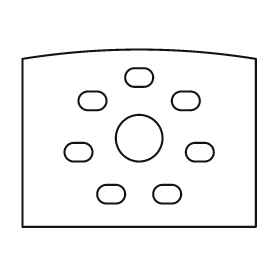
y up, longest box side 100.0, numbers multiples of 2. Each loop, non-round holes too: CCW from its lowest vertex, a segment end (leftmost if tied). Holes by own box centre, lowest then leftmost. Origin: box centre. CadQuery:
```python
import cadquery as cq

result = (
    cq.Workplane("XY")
    .moveTo(-50.0, -38.0)
    .lineTo(50.0, -38.0)
    .lineTo(50.0, 34.0)
    .threePointArc((0.0, 38.0), (-50.0, 34.0))
    .close()
    .moveTo(-14.0, -28.0)
    .lineTo(-10.0, -28.0)
    .threePointArc((-6.0, -24.0), (-10.0, -20.0))
    .lineTo(-14.0, -20.0)
    .threePointArc((-18.0, -24.0), (-14.0, -28.0))
    .close()
    .moveTo(10.0, -28.0)
    .lineTo(14.0, -28.0)
    .threePointArc((18.0, -24.0), (14.0, -20.0))
    .lineTo(10.0, -20.0)
    .threePointArc((6.0, -24.0), (10.0, -28.0))
    .close()
    .moveTo(-28.0, -10.0)
    .lineTo(-24.0, -10.0)
    .threePointArc((-20.0, -6.0), (-24.0, -2.0))
    .lineTo(-28.0, -2.0)
    .threePointArc((-32.0, -6.0), (-28.0, -10.0))
    .close()
    .moveTo(24.0, -10.0)
    .lineTo(28.0, -10.0)
    .threePointArc((32.0, -6.0), (28.0, -2.0))
    .lineTo(24.0, -2.0)
    .threePointArc((20.0, -6.0), (24.0, -10.0))
    .close()
    .moveTo(0.0, 0.0)
    .circle(10.0)
    .moveTo(-22.0, 12.0)
    .lineTo(-18.0, 12.0)
    .threePointArc((-14.0, 16.0), (-18.0, 20.0))
    .lineTo(-22.0, 20.0)
    .threePointArc((-26.0, 16.0), (-22.0, 12.0))
    .close()
    .moveTo(18.0, 12.0)
    .lineTo(22.0, 12.0)
    .threePointArc((26.0, 16.0), (22.0, 20.0))
    .lineTo(18.0, 20.0)
    .threePointArc((14.0, 16.0), (18.0, 12.0))
    .close()
    .moveTo(-2.0, 22.0)
    .lineTo(2.0, 22.0)
    .threePointArc((6.0, 26.0), (2.0, 30.0))
    .lineTo(-2.0, 30.0)
    .threePointArc((-6.0, 26.0), (-2.0, 22.0))
    .close()
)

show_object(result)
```